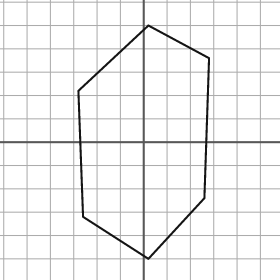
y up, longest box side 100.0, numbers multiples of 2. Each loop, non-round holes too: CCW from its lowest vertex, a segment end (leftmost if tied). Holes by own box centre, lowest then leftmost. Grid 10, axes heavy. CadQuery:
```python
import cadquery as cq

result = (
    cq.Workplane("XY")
    .moveTo(2.0, -50.0)
    .lineTo(26.0, -24.0)
    .lineTo(28.0, 36.0)
    .lineTo(2.0, 50.0)
    .lineTo(-28.0, 22.0)
    .lineTo(-26.0, -32.0)
    .close()
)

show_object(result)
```